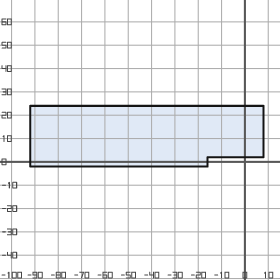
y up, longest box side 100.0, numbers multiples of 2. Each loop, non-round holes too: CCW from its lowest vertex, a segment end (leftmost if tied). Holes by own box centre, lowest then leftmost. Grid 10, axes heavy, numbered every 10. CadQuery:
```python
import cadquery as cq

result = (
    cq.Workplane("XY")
    .moveTo(-92.0, -2.0)
    .lineTo(-16.0, -2.0)
    .lineTo(-16.0, 2.0)
    .lineTo(8.0, 2.0)
    .lineTo(8.0, 24.0)
    .lineTo(-92.0, 24.0)
    .close()
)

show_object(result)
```